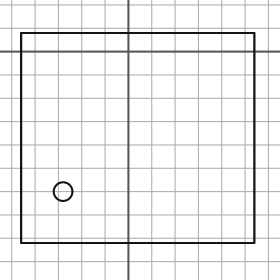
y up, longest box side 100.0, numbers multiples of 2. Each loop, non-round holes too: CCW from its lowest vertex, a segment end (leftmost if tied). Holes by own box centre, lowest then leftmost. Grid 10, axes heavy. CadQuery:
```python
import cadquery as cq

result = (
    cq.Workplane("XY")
    .moveTo(-46.0, -82.0)
    .lineTo(54.0, -82.0)
    .lineTo(54.0, 8.0)
    .lineTo(-46.0, 8.0)
    .close()
    .moveTo(-28.0, -60.0)
    .circle(4.0)
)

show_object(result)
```